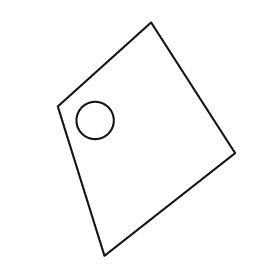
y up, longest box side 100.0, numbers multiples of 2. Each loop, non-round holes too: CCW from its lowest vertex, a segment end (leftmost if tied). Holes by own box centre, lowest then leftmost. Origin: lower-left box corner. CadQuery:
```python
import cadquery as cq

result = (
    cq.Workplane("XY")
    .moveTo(20.0, 0.0)
    .lineTo(76.0, 44.0)
    .lineTo(40.0, 100.0)
    .lineTo(0.0, 64.0)
    .close()
    .moveTo(16.0, 58.0)
    .circle(8.0)
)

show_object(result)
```